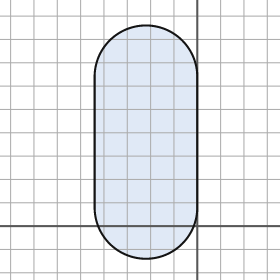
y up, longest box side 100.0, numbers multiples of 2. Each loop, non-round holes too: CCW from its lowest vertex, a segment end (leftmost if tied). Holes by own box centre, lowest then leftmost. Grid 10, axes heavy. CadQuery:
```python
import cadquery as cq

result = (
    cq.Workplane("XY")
    .moveTo(-44.0, 8.0)
    .threePointArc((-22.0, -14.0), (0.0, 8.0))
    .lineTo(0.0, 64.0)
    .threePointArc((-22.0, 86.0), (-44.0, 64.0))
    .close()
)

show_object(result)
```